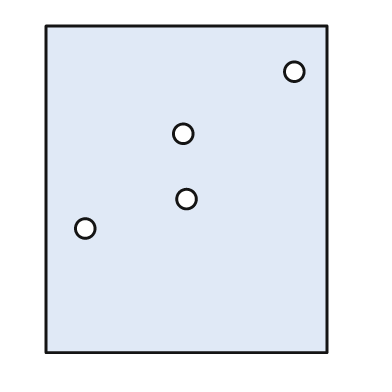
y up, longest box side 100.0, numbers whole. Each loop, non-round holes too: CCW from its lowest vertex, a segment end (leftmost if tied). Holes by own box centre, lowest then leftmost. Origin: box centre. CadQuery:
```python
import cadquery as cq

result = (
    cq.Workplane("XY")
    .moveTo(-43.0, -50.0)
    .lineTo(43.0, -50.0)
    .lineTo(43.0, 50.0)
    .lineTo(-43.0, 50.0)
    .close()
    .moveTo(-31.0, -12.0)
    .circle(3.0)
    .moveTo(0.0, -3.0)
    .circle(3.0)
    .moveTo(-1.0, 17.0)
    .circle(3.0)
    .moveTo(33.0, 36.0)
    .circle(3.0)
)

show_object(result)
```